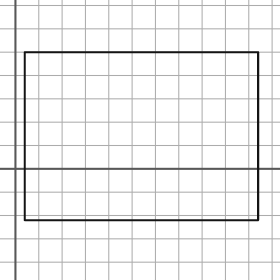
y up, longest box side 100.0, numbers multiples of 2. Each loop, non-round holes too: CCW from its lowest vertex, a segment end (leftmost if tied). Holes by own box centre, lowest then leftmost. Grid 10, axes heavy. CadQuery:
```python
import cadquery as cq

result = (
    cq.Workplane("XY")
    .moveTo(4.0, -22.0)
    .lineTo(104.0, -22.0)
    .lineTo(104.0, 50.0)
    .lineTo(4.0, 50.0)
    .close()
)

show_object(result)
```